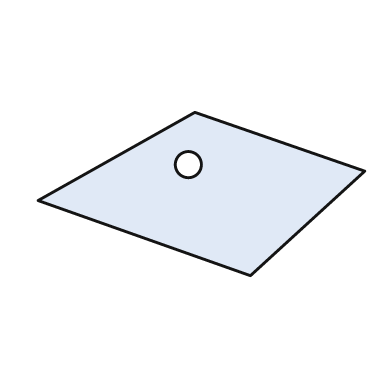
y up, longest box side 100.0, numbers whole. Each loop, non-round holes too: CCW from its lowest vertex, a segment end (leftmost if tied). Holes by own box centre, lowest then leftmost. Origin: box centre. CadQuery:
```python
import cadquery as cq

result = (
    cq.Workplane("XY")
    .moveTo(15.0, -25.0)
    .lineTo(50.0, 7.0)
    .lineTo(-2.0, 25.0)
    .lineTo(-50.0, -2.0)
    .close()
    .moveTo(-4.0, 9.0)
    .circle(4.0)
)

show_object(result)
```